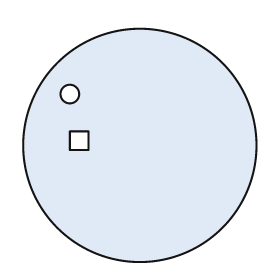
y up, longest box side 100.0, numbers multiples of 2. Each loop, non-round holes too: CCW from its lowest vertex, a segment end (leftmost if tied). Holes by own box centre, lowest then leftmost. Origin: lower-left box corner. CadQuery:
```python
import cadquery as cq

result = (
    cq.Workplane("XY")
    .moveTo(50.0, 50.0)
    .circle(50.0)
    .moveTo(20.0, 48.0)
    .lineTo(28.0, 48.0)
    .lineTo(28.0, 56.0)
    .lineTo(20.0, 56.0)
    .close()
    .moveTo(20.0, 72.0)
    .circle(4.0)
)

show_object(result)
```